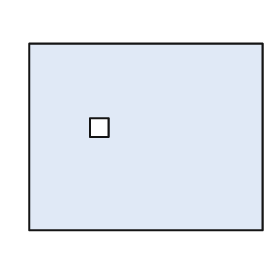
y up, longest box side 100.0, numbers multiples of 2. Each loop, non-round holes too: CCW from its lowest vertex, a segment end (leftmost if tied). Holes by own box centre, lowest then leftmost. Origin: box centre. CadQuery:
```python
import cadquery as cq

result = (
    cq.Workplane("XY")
    .moveTo(-50.0, -40.0)
    .lineTo(50.0, -40.0)
    .lineTo(50.0, 40.0)
    .lineTo(-50.0, 40.0)
    .close()
    .moveTo(-24.0, 0.0)
    .lineTo(-16.0, 0.0)
    .lineTo(-16.0, 8.0)
    .lineTo(-24.0, 8.0)
    .close()
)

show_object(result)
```